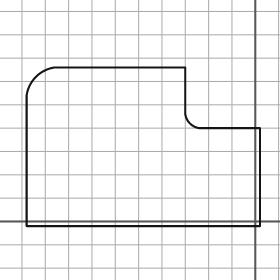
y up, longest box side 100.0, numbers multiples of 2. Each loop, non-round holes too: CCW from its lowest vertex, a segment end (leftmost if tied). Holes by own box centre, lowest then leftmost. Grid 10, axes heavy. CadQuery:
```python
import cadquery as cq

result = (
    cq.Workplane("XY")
    .moveTo(-98.0, -2.0)
    .lineTo(2.0, -2.0)
    .lineTo(2.0, 40.0)
    .lineTo(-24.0, 40.0)
    .threePointArc((-28.0, 42.0), (-30.0, 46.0))
    .lineTo(-30.0, 66.0)
    .lineTo(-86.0, 66.0)
    .threePointArc((-94.0, 62.0), (-98.0, 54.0))
    .close()
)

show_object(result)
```